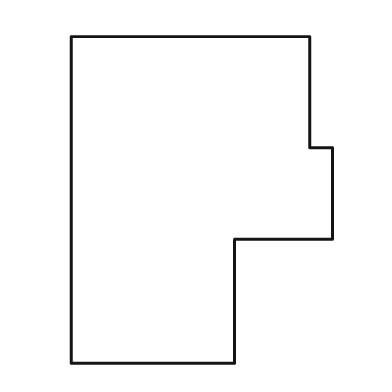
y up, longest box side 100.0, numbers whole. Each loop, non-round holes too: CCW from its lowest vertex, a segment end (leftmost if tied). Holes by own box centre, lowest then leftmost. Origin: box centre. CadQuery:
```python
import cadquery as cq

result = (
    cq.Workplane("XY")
    .moveTo(-40.0, -50.0)
    .lineTo(10.0, -50.0)
    .lineTo(10.0, -12.0)
    .lineTo(40.0, -12.0)
    .lineTo(40.0, 16.0)
    .lineTo(33.0, 16.0)
    .lineTo(33.0, 50.0)
    .lineTo(-40.0, 50.0)
    .close()
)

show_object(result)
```